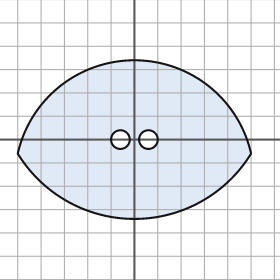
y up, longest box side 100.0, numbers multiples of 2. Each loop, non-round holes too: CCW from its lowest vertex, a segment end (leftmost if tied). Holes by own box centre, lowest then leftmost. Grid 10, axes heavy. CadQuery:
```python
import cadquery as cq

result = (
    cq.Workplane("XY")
    .moveTo(-50.0, -6.0)
    .threePointArc((0.0, -34.0), (50.0, -6.0))
    .threePointArc((0.0, 34.0), (-50.0, -6.0))
    .close()
    .moveTo(-6.0, 0.0)
    .circle(4.0)
    .moveTo(6.0, 0.0)
    .circle(4.0)
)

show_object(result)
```